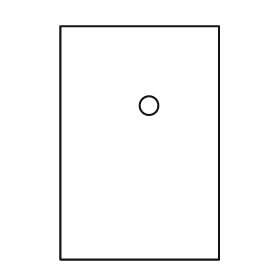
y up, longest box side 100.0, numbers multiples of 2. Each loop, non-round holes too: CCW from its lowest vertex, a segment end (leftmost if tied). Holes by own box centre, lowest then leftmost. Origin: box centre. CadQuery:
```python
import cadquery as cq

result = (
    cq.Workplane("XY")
    .moveTo(-34.0, -50.0)
    .lineTo(34.0, -50.0)
    .lineTo(34.0, 50.0)
    .lineTo(-34.0, 50.0)
    .close()
    .moveTo(4.0, 16.0)
    .circle(4.0)
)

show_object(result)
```